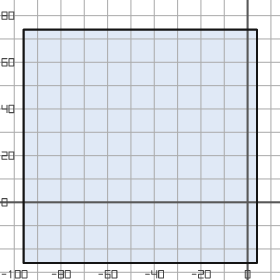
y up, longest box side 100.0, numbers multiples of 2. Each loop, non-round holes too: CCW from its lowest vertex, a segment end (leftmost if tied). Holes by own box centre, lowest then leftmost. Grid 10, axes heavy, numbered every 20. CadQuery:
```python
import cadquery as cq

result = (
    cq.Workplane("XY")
    .moveTo(-96.0, -26.0)
    .lineTo(4.0, -26.0)
    .lineTo(4.0, 74.0)
    .lineTo(-96.0, 74.0)
    .close()
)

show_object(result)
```